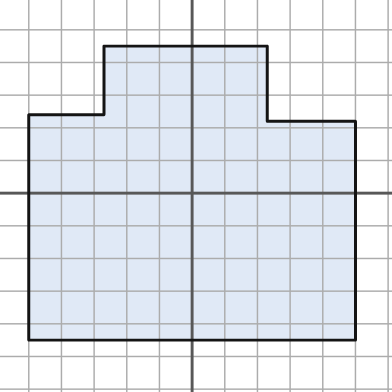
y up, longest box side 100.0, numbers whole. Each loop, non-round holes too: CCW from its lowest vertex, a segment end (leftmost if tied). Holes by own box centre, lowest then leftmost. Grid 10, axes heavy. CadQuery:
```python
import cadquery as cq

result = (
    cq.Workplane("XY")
    .moveTo(-50.0, -45.0)
    .lineTo(50.0, -45.0)
    .lineTo(50.0, 22.0)
    .lineTo(23.0, 22.0)
    .lineTo(23.0, 45.0)
    .lineTo(-27.0, 45.0)
    .lineTo(-27.0, 24.0)
    .lineTo(-50.0, 24.0)
    .close()
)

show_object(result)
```